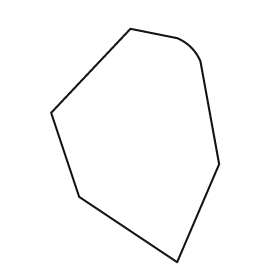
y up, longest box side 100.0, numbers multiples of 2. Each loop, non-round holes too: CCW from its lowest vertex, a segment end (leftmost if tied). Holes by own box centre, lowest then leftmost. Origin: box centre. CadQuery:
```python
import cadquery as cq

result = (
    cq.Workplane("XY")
    .moveTo(18.0, -50.0)
    .lineTo(36.0, -8.0)
    .lineTo(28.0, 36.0)
    .threePointArc((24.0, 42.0), (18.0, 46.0))
    .lineTo(-2.0, 50.0)
    .lineTo(-36.0, 14.0)
    .lineTo(-24.0, -22.0)
    .close()
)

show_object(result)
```